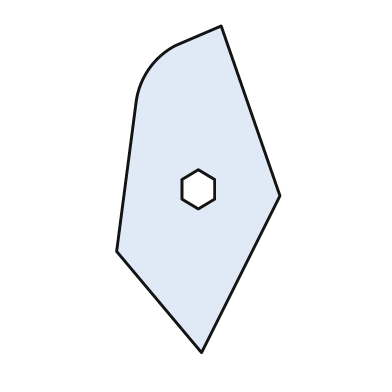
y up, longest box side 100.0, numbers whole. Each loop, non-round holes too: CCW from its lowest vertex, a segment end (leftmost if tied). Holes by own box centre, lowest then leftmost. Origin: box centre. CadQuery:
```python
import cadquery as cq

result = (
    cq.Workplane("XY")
    .moveTo(1.0, -50.0)
    .lineTo(25.0, -2.0)
    .lineTo(7.0, 50.0)
    .lineTo(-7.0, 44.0)
    .threePointArc((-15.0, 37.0), (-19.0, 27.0))
    .lineTo(-25.0, -19.0)
    .close()
    .moveTo(0.0, -6.0)
    .lineTo(5.0, -3.0)
    .lineTo(5.0, 3.0)
    .lineTo(0.0, 6.0)
    .lineTo(-5.0, 3.0)
    .lineTo(-5.0, -3.0)
    .close()
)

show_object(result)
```